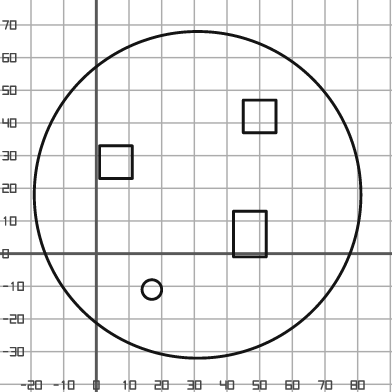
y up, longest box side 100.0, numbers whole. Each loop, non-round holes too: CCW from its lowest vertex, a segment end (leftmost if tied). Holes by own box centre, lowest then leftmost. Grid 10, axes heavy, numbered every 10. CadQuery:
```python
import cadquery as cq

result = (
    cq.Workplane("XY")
    .moveTo(31.0, 18.0)
    .circle(50.0)
    .moveTo(17.0, -11.0)
    .circle(3.0)
    .moveTo(42.0, -1.0)
    .lineTo(52.0, -1.0)
    .lineTo(52.0, 13.0)
    .lineTo(42.0, 13.0)
    .close()
    .moveTo(1.0, 23.0)
    .lineTo(11.0, 23.0)
    .lineTo(11.0, 33.0)
    .lineTo(1.0, 33.0)
    .close()
    .moveTo(45.0, 37.0)
    .lineTo(55.0, 37.0)
    .lineTo(55.0, 47.0)
    .lineTo(45.0, 47.0)
    .close()
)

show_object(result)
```